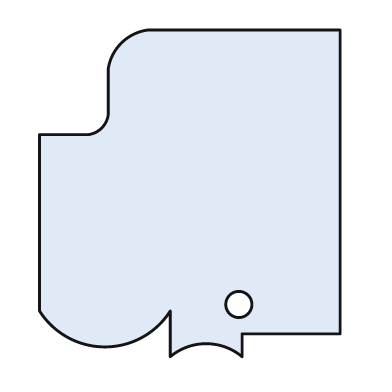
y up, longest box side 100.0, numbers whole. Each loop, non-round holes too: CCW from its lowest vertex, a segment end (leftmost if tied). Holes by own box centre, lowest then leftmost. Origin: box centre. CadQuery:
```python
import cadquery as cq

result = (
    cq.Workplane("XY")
    .moveTo(-6.0, -50.0)
    .threePointArc((5.0, -46.0), (16.0, -50.0))
    .lineTo(16.0, -43.0)
    .lineTo(46.0, -43.0)
    .lineTo(46.0, 50.0)
    .lineTo(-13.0, 50.0)
    .threePointArc((-21.0, 46.0), (-25.0, 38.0))
    .lineTo(-25.0, 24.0)
    .threePointArc((-27.0, 20.0), (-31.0, 18.0))
    .lineTo(-46.0, 18.0)
    .lineTo(-46.0, -36.0)
    .threePointArc((-26.0, -47.0), (-6.0, -36.0))
    .close()
    .moveTo(15.0, -34.0)
    .circle(4.0)
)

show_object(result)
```